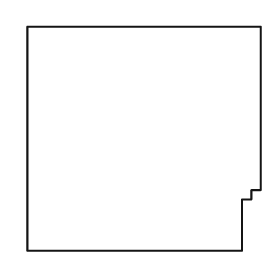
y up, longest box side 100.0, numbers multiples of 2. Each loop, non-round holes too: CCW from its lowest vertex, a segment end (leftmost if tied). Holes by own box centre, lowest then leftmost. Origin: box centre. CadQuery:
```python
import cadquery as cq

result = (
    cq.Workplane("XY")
    .moveTo(-50.0, -48.0)
    .lineTo(42.0, -48.0)
    .lineTo(42.0, -26.0)
    .lineTo(46.0, -26.0)
    .lineTo(46.0, -22.0)
    .lineTo(50.0, -22.0)
    .lineTo(50.0, 48.0)
    .lineTo(-50.0, 48.0)
    .close()
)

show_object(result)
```